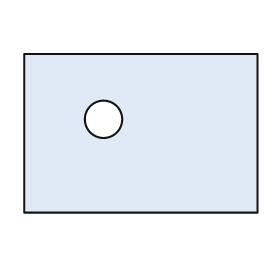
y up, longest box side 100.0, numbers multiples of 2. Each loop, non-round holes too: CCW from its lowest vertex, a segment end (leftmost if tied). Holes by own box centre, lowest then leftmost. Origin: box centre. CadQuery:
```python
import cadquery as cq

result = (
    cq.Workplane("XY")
    .moveTo(-50.0, -34.0)
    .lineTo(50.0, -34.0)
    .lineTo(50.0, 34.0)
    .lineTo(-50.0, 34.0)
    .close()
    .moveTo(-16.0, 6.0)
    .circle(8.0)
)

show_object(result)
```